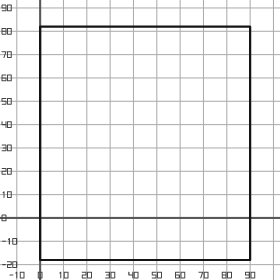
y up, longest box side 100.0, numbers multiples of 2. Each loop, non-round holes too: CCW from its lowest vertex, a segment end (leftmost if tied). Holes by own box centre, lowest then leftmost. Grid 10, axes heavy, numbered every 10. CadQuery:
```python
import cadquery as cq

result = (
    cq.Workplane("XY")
    .moveTo(0.0, -18.0)
    .lineTo(90.0, -18.0)
    .lineTo(90.0, 82.0)
    .lineTo(0.0, 82.0)
    .close()
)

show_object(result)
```